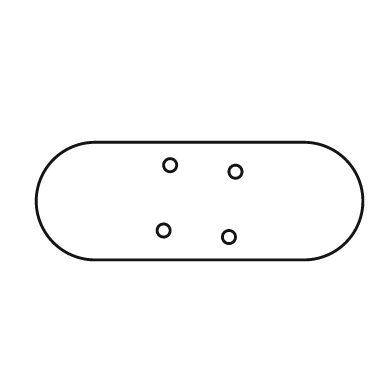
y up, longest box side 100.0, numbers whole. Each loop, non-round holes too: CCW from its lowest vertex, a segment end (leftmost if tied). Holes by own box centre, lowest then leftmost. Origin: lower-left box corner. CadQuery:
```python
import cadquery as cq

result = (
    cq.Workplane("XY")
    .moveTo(18.0, 0.0)
    .lineTo(82.0, 0.0)
    .threePointArc((100.0, 18.0), (82.0, 36.0))
    .lineTo(18.0, 36.0)
    .threePointArc((0.0, 18.0), (18.0, 0.0))
    .close()
    .moveTo(59.0, 7.0)
    .circle(2.0)
    .moveTo(39.0, 9.0)
    .circle(2.0)
    .moveTo(61.0, 27.0)
    .circle(2.0)
    .moveTo(41.0, 29.0)
    .circle(2.0)
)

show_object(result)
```